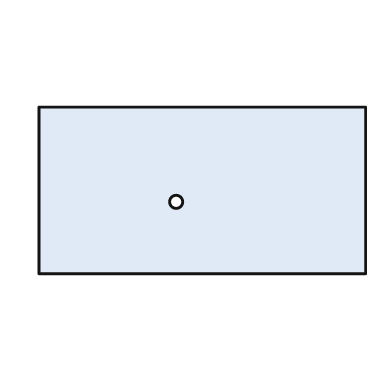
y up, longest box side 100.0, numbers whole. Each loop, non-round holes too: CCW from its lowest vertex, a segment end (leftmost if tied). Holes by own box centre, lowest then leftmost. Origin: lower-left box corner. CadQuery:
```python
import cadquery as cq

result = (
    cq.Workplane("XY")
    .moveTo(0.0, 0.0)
    .lineTo(100.0, 0.0)
    .lineTo(100.0, 51.0)
    .lineTo(0.0, 51.0)
    .close()
    .moveTo(42.0, 22.0)
    .circle(2.0)
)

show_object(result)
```